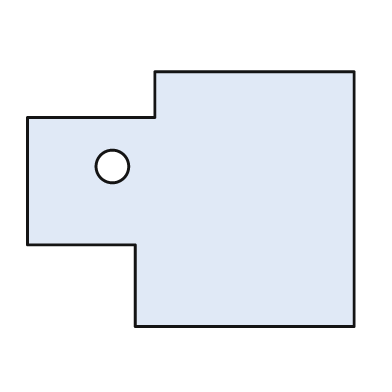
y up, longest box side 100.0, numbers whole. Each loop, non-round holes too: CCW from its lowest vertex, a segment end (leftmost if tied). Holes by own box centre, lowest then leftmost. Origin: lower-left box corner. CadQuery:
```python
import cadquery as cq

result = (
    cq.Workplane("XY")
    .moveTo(33.0, 0.0)
    .lineTo(100.0, 0.0)
    .lineTo(100.0, 78.0)
    .lineTo(39.0, 78.0)
    .lineTo(39.0, 64.0)
    .lineTo(0.0, 64.0)
    .lineTo(0.0, 25.0)
    .lineTo(33.0, 25.0)
    .close()
    .moveTo(26.0, 49.0)
    .circle(5.0)
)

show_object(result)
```